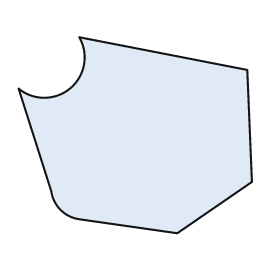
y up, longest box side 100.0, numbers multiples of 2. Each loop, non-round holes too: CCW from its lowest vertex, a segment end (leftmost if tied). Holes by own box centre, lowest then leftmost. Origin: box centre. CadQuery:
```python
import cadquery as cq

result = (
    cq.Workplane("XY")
    .moveTo(18.0, -42.0)
    .lineTo(50.0, -20.0)
    .lineTo(48.0, 28.0)
    .lineTo(-24.0, 42.0)
    .threePointArc((-28.0, 20.0), (-50.0, 20.0))
    .lineTo(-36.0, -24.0)
    .threePointArc((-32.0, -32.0), (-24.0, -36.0))
    .close()
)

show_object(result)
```